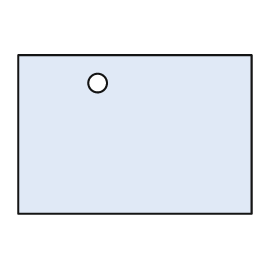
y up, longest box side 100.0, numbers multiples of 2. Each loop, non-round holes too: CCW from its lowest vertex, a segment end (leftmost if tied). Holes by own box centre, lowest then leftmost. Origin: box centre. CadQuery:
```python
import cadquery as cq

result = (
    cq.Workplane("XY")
    .moveTo(-50.0, -34.0)
    .lineTo(50.0, -34.0)
    .lineTo(50.0, 34.0)
    .lineTo(-50.0, 34.0)
    .close()
    .moveTo(-16.0, 22.0)
    .circle(4.0)
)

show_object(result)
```